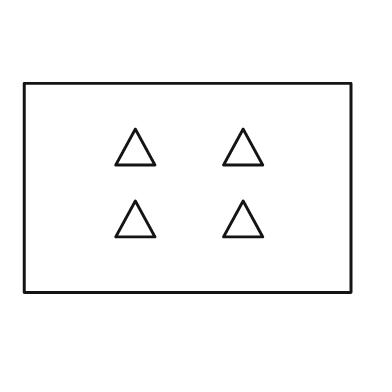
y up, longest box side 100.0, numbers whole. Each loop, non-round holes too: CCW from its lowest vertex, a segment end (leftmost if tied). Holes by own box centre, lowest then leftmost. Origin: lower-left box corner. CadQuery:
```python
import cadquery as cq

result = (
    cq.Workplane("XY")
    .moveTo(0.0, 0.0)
    .lineTo(100.0, 0.0)
    .lineTo(100.0, 64.0)
    .lineTo(0.0, 64.0)
    .close()
    .moveTo(28.0, 17.0)
    .lineTo(40.0, 17.0)
    .lineTo(34.0, 28.0)
    .close()
    .moveTo(61.0, 17.0)
    .lineTo(73.0, 17.0)
    .lineTo(67.0, 28.0)
    .close()
    .moveTo(28.0, 39.0)
    .lineTo(40.0, 39.0)
    .lineTo(34.0, 50.0)
    .close()
    .moveTo(61.0, 39.0)
    .lineTo(73.0, 39.0)
    .lineTo(67.0, 50.0)
    .close()
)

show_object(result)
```